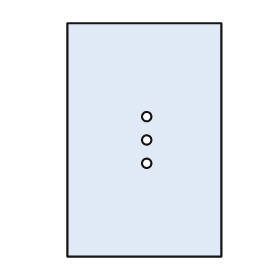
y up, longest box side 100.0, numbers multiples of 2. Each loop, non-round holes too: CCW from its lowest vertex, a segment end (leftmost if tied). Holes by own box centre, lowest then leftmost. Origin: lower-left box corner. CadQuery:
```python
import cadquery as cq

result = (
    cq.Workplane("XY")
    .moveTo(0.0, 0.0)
    .lineTo(66.0, 0.0)
    .lineTo(66.0, 100.0)
    .lineTo(0.0, 100.0)
    .close()
    .moveTo(34.0, 40.0)
    .circle(2.0)
    .moveTo(34.0, 50.0)
    .circle(2.0)
    .moveTo(34.0, 60.0)
    .circle(2.0)
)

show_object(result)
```